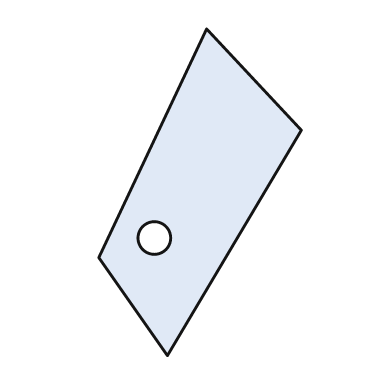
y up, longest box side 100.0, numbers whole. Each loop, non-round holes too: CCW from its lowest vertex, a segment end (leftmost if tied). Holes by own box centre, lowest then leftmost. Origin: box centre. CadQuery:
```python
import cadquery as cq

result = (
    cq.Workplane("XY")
    .moveTo(-10.0, -50.0)
    .lineTo(31.0, 19.0)
    .lineTo(2.0, 50.0)
    .lineTo(-31.0, -20.0)
    .close()
    .moveTo(-14.0, -14.0)
    .circle(5.0)
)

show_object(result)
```